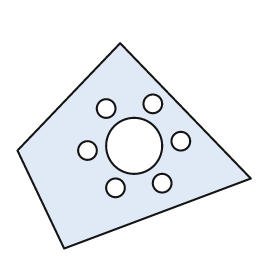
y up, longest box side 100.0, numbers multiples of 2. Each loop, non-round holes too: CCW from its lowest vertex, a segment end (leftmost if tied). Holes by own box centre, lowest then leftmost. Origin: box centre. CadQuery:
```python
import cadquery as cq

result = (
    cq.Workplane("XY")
    .moveTo(-30.0, -44.0)
    .lineTo(50.0, -14.0)
    .lineTo(-6.0, 44.0)
    .lineTo(-50.0, -2.0)
    .close()
    .moveTo(-8.0, -18.0)
    .circle(4.0)
    .moveTo(12.0, -16.0)
    .circle(4.0)
    .moveTo(-20.0, -2.0)
    .circle(4.0)
    .moveTo(0.0, 0.0)
    .circle(12.0)
    .moveTo(20.0, 2.0)
    .circle(4.0)
    .moveTo(-12.0, 16.0)
    .circle(4.0)
    .moveTo(8.0, 18.0)
    .circle(4.0)
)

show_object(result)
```